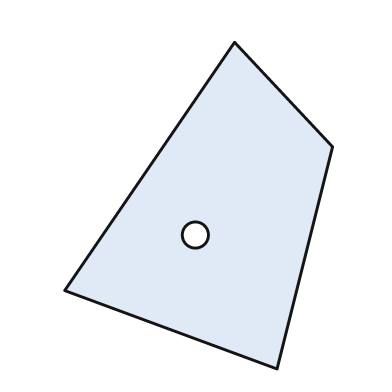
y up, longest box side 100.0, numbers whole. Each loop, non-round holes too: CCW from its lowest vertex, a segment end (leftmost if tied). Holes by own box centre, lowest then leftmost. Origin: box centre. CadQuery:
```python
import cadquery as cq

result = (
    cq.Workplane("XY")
    .moveTo(24.0, -50.0)
    .lineTo(41.0, 18.0)
    .lineTo(11.0, 50.0)
    .lineTo(-41.0, -26.0)
    .close()
    .moveTo(-1.0, -9.0)
    .circle(4.0)
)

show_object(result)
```